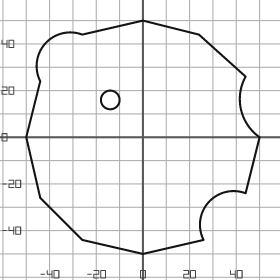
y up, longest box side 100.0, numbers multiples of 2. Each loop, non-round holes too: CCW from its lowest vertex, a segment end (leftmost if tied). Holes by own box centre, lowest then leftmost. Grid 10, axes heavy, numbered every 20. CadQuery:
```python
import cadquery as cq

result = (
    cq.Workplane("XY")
    .moveTo(0.0, -50.0)
    .lineTo(26.0, -44.0)
    .threePointArc((28.0, -28.0), (44.0, -24.0))
    .lineTo(50.0, 0.0)
    .threePointArc((42.0, 12.0), (44.0, 26.0))
    .lineTo(24.0, 44.0)
    .lineTo(0.0, 50.0)
    .lineTo(-26.0, 44.0)
    .threePointArc((-42.0, 40.0), (-44.0, 24.0))
    .lineTo(-50.0, 0.0)
    .lineTo(-44.0, -26.0)
    .lineTo(-26.0, -44.0)
    .close()
    .moveTo(-14.0, 16.0)
    .circle(4.0)
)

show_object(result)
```